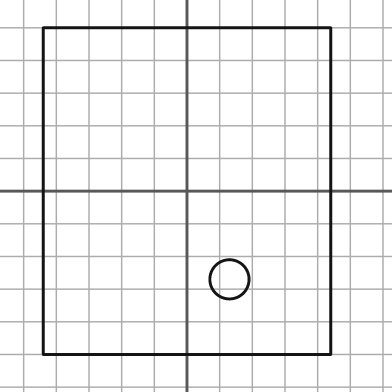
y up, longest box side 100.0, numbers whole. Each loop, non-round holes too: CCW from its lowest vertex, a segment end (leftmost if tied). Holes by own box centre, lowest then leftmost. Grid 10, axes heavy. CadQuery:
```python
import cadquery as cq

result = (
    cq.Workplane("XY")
    .moveTo(-44.0, -50.0)
    .lineTo(44.0, -50.0)
    .lineTo(44.0, 50.0)
    .lineTo(-44.0, 50.0)
    .close()
    .moveTo(13.0, -27.0)
    .circle(6.0)
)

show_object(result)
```